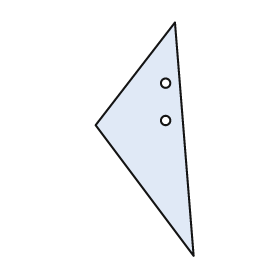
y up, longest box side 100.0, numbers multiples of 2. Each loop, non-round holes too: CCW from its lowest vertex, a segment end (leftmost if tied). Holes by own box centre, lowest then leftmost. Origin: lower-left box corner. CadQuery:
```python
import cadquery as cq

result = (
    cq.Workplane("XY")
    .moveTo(42.0, 0.0)
    .lineTo(34.0, 100.0)
    .lineTo(0.0, 56.0)
    .close()
    .moveTo(30.0, 58.0)
    .circle(2.0)
    .moveTo(30.0, 74.0)
    .circle(2.0)
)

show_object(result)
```